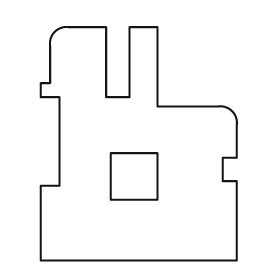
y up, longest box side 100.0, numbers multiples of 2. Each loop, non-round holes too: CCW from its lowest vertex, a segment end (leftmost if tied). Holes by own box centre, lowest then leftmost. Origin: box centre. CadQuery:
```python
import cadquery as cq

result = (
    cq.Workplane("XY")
    .moveTo(-42.0, -50.0)
    .lineTo(42.0, -50.0)
    .lineTo(42.0, -16.0)
    .lineTo(36.0, -16.0)
    .lineTo(36.0, -6.0)
    .lineTo(42.0, -6.0)
    .lineTo(42.0, 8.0)
    .threePointArc((40.0, 14.0), (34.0, 16.0))
    .lineTo(8.0, 16.0)
    .lineTo(8.0, 50.0)
    .lineTo(-4.0, 50.0)
    .lineTo(-4.0, 20.0)
    .lineTo(-14.0, 20.0)
    .lineTo(-14.0, 50.0)
    .lineTo(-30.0, 50.0)
    .threePointArc((-36.0, 48.0), (-38.0, 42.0))
    .lineTo(-38.0, 26.0)
    .lineTo(-42.0, 26.0)
    .lineTo(-42.0, 20.0)
    .lineTo(-34.0, 20.0)
    .lineTo(-34.0, -18.0)
    .lineTo(-42.0, -18.0)
    .close()
    .moveTo(-12.0, -24.0)
    .lineTo(8.0, -24.0)
    .lineTo(8.0, -4.0)
    .lineTo(-12.0, -4.0)
    .close()
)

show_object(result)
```